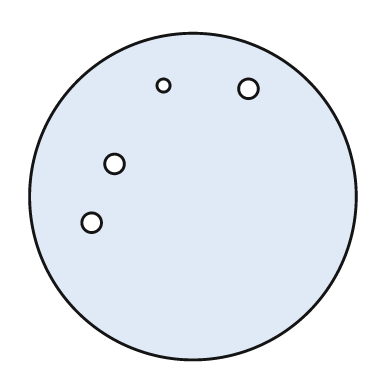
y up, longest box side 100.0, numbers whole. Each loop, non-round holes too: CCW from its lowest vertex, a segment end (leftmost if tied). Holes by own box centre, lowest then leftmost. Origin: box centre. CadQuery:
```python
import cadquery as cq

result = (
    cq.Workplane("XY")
    .moveTo(0.0, 0.0)
    .circle(50.0)
    .moveTo(-31.0, -8.0)
    .circle(3.0)
    .moveTo(-24.0, 10.0)
    .circle(3.0)
    .moveTo(17.0, 33.0)
    .circle(3.0)
    .moveTo(-9.0, 34.0)
    .circle(2.0)
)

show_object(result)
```